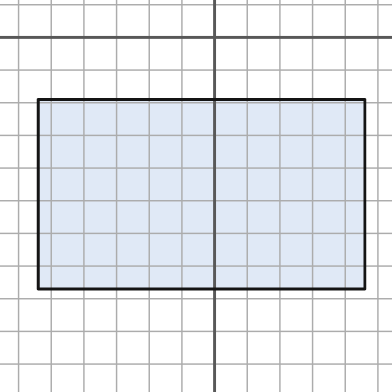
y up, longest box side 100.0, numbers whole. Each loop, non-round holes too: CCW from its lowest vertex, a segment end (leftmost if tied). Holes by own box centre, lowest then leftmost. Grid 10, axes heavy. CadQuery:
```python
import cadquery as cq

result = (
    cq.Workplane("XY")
    .moveTo(-54.0, -77.0)
    .lineTo(46.0, -77.0)
    .lineTo(46.0, -19.0)
    .lineTo(-54.0, -19.0)
    .close()
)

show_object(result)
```